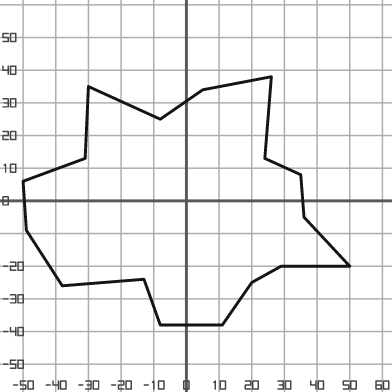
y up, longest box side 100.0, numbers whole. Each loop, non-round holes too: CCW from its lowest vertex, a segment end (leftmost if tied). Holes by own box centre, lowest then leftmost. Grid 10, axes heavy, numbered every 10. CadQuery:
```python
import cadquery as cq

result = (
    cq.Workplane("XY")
    .moveTo(-8.0, -38.0)
    .lineTo(11.0, -38.0)
    .lineTo(20.0, -25.0)
    .lineTo(29.0, -20.0)
    .lineTo(50.0, -20.0)
    .lineTo(36.0, -5.0)
    .lineTo(35.0, 8.0)
    .lineTo(24.0, 13.0)
    .lineTo(26.0, 38.0)
    .lineTo(5.0, 34.0)
    .lineTo(-8.0, 25.0)
    .lineTo(-30.0, 35.0)
    .lineTo(-31.0, 13.0)
    .lineTo(-50.0, 6.0)
    .lineTo(-49.0, -9.0)
    .lineTo(-38.0, -26.0)
    .lineTo(-13.0, -24.0)
    .close()
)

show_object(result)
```